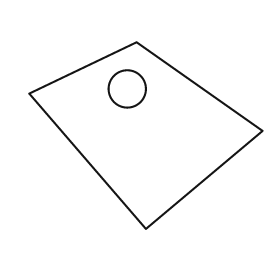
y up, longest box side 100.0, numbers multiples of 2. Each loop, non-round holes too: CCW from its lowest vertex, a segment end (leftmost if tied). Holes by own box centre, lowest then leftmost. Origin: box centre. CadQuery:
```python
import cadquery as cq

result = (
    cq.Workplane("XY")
    .moveTo(0.0, -40.0)
    .lineTo(50.0, 2.0)
    .lineTo(-4.0, 40.0)
    .lineTo(-50.0, 18.0)
    .close()
    .moveTo(-8.0, 20.0)
    .circle(8.0)
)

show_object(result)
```